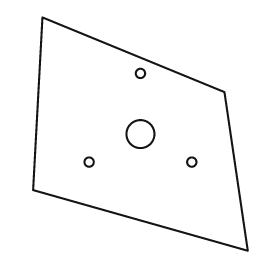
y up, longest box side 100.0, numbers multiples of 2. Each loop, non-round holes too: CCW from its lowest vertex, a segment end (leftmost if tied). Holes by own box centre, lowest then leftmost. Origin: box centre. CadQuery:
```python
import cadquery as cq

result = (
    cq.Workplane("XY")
    .moveTo(46.0, -50.0)
    .lineTo(36.0, 18.0)
    .lineTo(-42.0, 50.0)
    .lineTo(-46.0, -24.0)
    .close()
    .moveTo(-22.0, -12.0)
    .circle(2.0)
    .moveTo(22.0, -12.0)
    .circle(2.0)
    .moveTo(0.0, 0.0)
    .circle(6.0)
    .moveTo(0.0, 26.0)
    .circle(2.0)
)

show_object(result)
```